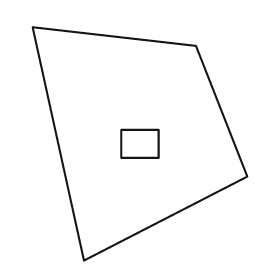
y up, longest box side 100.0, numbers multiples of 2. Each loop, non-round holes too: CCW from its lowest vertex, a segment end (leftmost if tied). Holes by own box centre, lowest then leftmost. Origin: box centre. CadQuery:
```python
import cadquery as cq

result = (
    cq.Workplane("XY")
    .moveTo(-24.0, -50.0)
    .lineTo(46.0, -14.0)
    .lineTo(24.0, 42.0)
    .lineTo(-46.0, 50.0)
    .close()
    .moveTo(-8.0, -6.0)
    .lineTo(8.0, -6.0)
    .lineTo(8.0, 6.0)
    .lineTo(-8.0, 6.0)
    .close()
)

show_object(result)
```